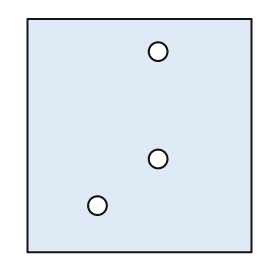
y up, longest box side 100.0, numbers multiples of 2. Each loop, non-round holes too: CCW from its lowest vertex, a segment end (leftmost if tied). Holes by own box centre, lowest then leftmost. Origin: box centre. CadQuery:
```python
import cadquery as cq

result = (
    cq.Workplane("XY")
    .moveTo(-48.0, -50.0)
    .lineTo(48.0, -50.0)
    .lineTo(48.0, 50.0)
    .lineTo(-48.0, 50.0)
    .close()
    .moveTo(-18.0, -30.0)
    .circle(4.0)
    .moveTo(8.0, -10.0)
    .circle(4.0)
    .moveTo(8.0, 36.0)
    .circle(4.0)
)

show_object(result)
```